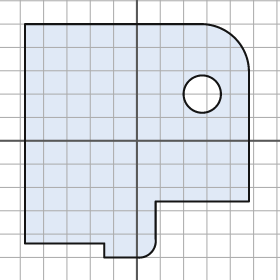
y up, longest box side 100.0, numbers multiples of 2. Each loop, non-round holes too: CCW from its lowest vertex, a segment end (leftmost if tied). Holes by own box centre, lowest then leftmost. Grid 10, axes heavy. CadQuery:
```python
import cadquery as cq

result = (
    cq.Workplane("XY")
    .moveTo(-14.0, -50.0)
    .lineTo(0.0, -50.0)
    .threePointArc((6.0, -48.0), (8.0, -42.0))
    .lineTo(8.0, -26.0)
    .lineTo(48.0, -26.0)
    .lineTo(48.0, 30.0)
    .threePointArc((42.0, 44.0), (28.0, 50.0))
    .lineTo(-48.0, 50.0)
    .lineTo(-48.0, -44.0)
    .lineTo(-14.0, -44.0)
    .close()
    .moveTo(28.0, 20.0)
    .circle(8.0)
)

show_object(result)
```